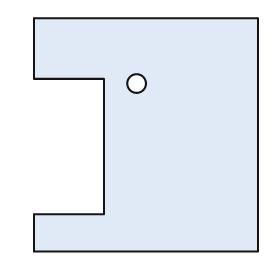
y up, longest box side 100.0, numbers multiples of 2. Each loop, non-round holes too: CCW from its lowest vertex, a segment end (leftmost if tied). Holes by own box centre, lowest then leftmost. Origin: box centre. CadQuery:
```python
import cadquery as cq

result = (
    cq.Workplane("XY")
    .moveTo(-48.0, -50.0)
    .lineTo(48.0, -50.0)
    .lineTo(48.0, 50.0)
    .lineTo(-48.0, 50.0)
    .lineTo(-48.0, 24.0)
    .lineTo(-18.0, 24.0)
    .lineTo(-18.0, -34.0)
    .lineTo(-48.0, -34.0)
    .close()
    .moveTo(-4.0, 22.0)
    .circle(4.0)
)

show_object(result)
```